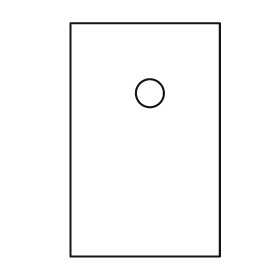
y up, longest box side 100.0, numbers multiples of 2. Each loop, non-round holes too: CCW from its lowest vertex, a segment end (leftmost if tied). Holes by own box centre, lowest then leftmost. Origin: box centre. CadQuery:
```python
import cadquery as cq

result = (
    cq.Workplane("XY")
    .moveTo(-32.0, -50.0)
    .lineTo(32.0, -50.0)
    .lineTo(32.0, 50.0)
    .lineTo(-32.0, 50.0)
    .close()
    .moveTo(2.0, 20.0)
    .circle(6.0)
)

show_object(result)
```